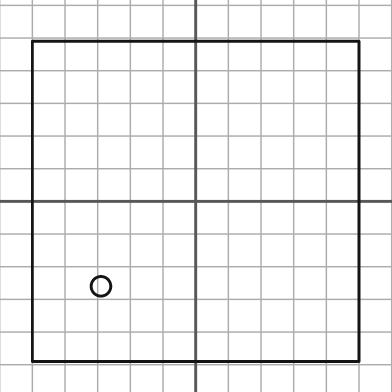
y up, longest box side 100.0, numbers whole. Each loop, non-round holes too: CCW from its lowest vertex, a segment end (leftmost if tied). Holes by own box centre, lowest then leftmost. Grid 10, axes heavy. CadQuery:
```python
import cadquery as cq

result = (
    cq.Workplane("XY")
    .moveTo(-50.0, -49.0)
    .lineTo(50.0, -49.0)
    .lineTo(50.0, 49.0)
    .lineTo(-50.0, 49.0)
    .close()
    .moveTo(-29.0, -26.0)
    .circle(3.0)
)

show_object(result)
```